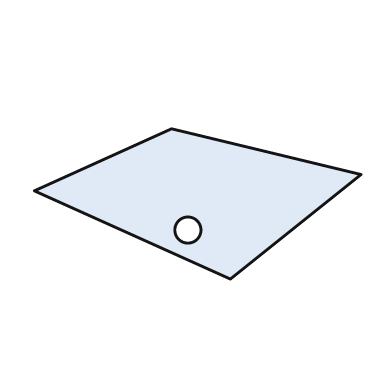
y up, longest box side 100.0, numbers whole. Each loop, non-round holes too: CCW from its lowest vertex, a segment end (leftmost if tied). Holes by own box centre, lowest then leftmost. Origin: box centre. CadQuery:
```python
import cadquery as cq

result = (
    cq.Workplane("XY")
    .moveTo(10.0, -23.0)
    .lineTo(50.0, 9.0)
    .lineTo(-8.0, 23.0)
    .lineTo(-50.0, 4.0)
    .close()
    .moveTo(-3.0, -8.0)
    .circle(4.0)
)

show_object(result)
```